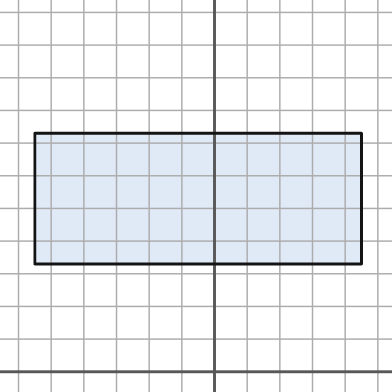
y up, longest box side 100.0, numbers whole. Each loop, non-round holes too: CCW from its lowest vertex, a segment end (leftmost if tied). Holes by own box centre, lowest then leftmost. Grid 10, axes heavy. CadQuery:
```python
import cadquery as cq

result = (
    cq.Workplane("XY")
    .moveTo(-55.0, 33.0)
    .lineTo(45.0, 33.0)
    .lineTo(45.0, 73.0)
    .lineTo(-55.0, 73.0)
    .close()
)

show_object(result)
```